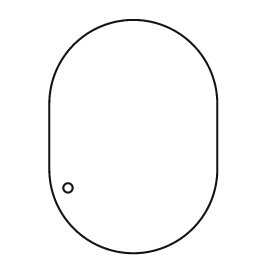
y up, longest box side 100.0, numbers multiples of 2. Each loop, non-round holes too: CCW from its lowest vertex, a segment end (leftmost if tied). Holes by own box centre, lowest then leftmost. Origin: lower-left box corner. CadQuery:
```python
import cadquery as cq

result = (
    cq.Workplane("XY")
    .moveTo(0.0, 36.0)
    .threePointArc((36.0, 0.0), (72.0, 36.0))
    .lineTo(72.0, 64.0)
    .threePointArc((36.0, 100.0), (0.0, 64.0))
    .close()
    .moveTo(8.0, 28.0)
    .circle(2.0)
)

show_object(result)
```